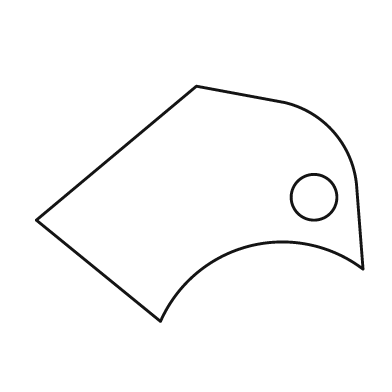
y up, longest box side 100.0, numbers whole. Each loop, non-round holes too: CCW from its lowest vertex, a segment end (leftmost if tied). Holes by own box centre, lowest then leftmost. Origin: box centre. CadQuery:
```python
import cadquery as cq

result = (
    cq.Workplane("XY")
    .moveTo(-12.0, -36.0)
    .threePointArc((15.0, -13.0), (50.0, -20.0))
    .lineTo(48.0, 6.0)
    .threePointArc((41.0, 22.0), (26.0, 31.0))
    .lineTo(-1.0, 36.0)
    .lineTo(-50.0, -5.0)
    .close()
    .moveTo(35.0, 2.0)
    .circle(7.0)
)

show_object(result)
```